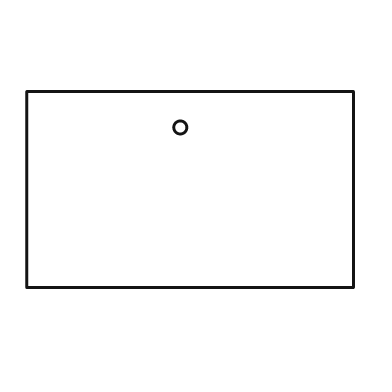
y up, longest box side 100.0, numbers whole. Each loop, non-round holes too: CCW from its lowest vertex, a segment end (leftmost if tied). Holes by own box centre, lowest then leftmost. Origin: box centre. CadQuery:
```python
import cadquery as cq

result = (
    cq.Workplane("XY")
    .moveTo(-50.0, -30.0)
    .lineTo(50.0, -30.0)
    .lineTo(50.0, 30.0)
    .lineTo(-50.0, 30.0)
    .close()
    .moveTo(-3.0, 19.0)
    .circle(2.0)
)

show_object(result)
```